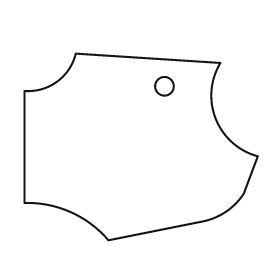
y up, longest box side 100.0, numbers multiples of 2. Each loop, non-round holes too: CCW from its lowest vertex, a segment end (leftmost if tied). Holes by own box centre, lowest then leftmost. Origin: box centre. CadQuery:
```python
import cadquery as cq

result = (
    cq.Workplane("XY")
    .moveTo(-14.0, -40.0)
    .lineTo(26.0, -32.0)
    .threePointArc((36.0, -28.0), (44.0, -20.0))
    .lineTo(50.0, -4.0)
    .threePointArc((32.0, 12.0), (34.0, 36.0))
    .lineTo(-28.0, 40.0)
    .threePointArc((-36.0, 28.0), (-50.0, 24.0))
    .lineTo(-50.0, -24.0)
    .threePointArc((-30.0, -28.0), (-14.0, -40.0))
    .close()
    .moveTo(10.0, 26.0)
    .circle(4.0)
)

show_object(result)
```